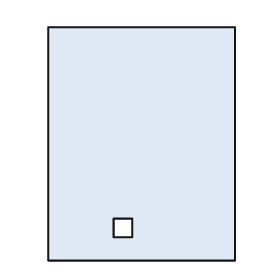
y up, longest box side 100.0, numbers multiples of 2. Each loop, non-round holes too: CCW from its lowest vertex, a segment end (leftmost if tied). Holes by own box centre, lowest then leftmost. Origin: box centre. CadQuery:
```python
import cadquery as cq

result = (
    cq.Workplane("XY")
    .moveTo(-40.0, -50.0)
    .lineTo(40.0, -50.0)
    .lineTo(40.0, 50.0)
    .lineTo(-40.0, 50.0)
    .close()
    .moveTo(-12.0, -40.0)
    .lineTo(-4.0, -40.0)
    .lineTo(-4.0, -32.0)
    .lineTo(-12.0, -32.0)
    .close()
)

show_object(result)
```